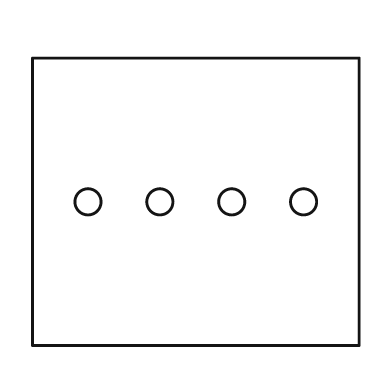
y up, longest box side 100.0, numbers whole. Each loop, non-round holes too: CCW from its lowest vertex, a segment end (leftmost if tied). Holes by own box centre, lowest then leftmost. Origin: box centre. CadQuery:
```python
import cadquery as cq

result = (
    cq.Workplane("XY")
    .moveTo(-50.0, -44.0)
    .lineTo(50.0, -44.0)
    .lineTo(50.0, 44.0)
    .lineTo(-50.0, 44.0)
    .close()
    .moveTo(-33.0, 0.0)
    .circle(4.0)
    .moveTo(-11.0, 0.0)
    .circle(4.0)
    .moveTo(11.0, 0.0)
    .circle(4.0)
    .moveTo(33.0, 0.0)
    .circle(4.0)
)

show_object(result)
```